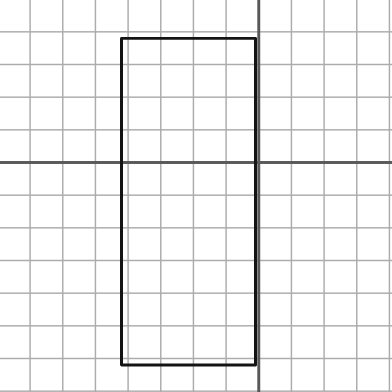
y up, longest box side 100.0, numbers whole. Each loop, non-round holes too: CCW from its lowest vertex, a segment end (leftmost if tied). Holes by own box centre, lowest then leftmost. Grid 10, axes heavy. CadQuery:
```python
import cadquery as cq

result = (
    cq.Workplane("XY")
    .moveTo(-42.0, -62.0)
    .lineTo(-1.0, -62.0)
    .lineTo(-1.0, 38.0)
    .lineTo(-42.0, 38.0)
    .close()
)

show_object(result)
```